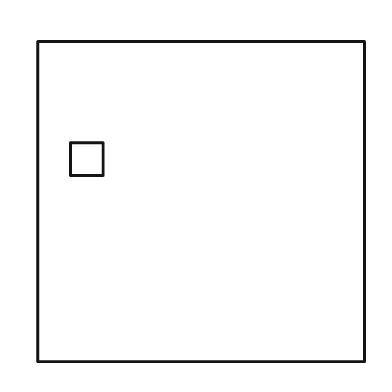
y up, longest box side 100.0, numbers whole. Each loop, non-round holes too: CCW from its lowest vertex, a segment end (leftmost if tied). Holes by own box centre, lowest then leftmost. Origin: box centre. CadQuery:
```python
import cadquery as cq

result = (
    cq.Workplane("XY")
    .moveTo(-50.0, -49.0)
    .lineTo(50.0, -49.0)
    .lineTo(50.0, 49.0)
    .lineTo(-50.0, 49.0)
    .close()
    .moveTo(-40.0, 8.0)
    .lineTo(-30.0, 8.0)
    .lineTo(-30.0, 18.0)
    .lineTo(-40.0, 18.0)
    .close()
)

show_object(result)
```